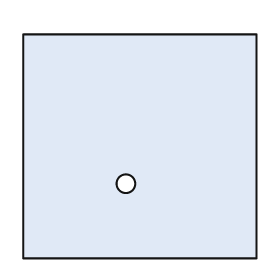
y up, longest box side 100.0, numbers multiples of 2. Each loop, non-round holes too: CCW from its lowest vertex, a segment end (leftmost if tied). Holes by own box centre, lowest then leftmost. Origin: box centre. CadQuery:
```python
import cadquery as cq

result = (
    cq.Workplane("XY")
    .moveTo(-50.0, -48.0)
    .lineTo(50.0, -48.0)
    .lineTo(50.0, 48.0)
    .lineTo(-50.0, 48.0)
    .close()
    .moveTo(-6.0, -16.0)
    .circle(4.0)
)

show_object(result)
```